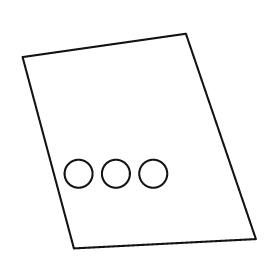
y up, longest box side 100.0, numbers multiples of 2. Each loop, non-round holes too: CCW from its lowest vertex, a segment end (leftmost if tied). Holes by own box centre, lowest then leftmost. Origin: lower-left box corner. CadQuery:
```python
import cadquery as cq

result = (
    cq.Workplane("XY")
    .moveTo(22.0, 0.0)
    .lineTo(100.0, 4.0)
    .lineTo(70.0, 92.0)
    .lineTo(0.0, 82.0)
    .close()
    .moveTo(24.0, 32.0)
    .circle(6.0)
    .moveTo(40.0, 32.0)
    .circle(6.0)
    .moveTo(56.0, 32.0)
    .circle(6.0)
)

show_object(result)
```